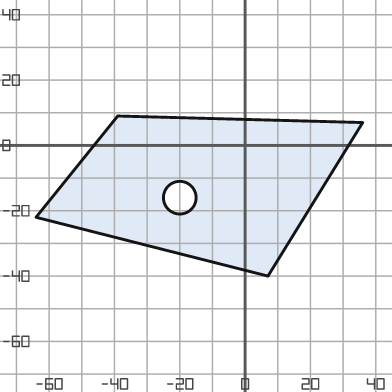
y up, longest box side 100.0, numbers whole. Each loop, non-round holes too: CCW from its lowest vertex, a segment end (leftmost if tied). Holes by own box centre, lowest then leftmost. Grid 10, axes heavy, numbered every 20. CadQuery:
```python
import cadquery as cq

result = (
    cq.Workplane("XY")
    .moveTo(7.0, -40.0)
    .lineTo(36.0, 7.0)
    .lineTo(-39.0, 9.0)
    .lineTo(-64.0, -22.0)
    .close()
    .moveTo(-20.0, -16.0)
    .circle(5.0)
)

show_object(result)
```